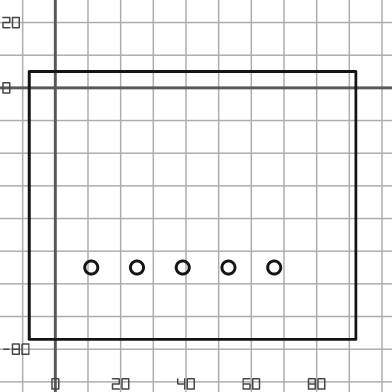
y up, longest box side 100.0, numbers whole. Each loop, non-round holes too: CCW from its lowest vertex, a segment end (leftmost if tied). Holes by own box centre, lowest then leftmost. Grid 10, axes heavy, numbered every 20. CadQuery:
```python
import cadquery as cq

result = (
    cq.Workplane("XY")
    .moveTo(-8.0, -77.0)
    .lineTo(92.0, -77.0)
    .lineTo(92.0, 5.0)
    .lineTo(-8.0, 5.0)
    .close()
    .moveTo(11.0, -55.0)
    .circle(2.0)
    .moveTo(25.0, -55.0)
    .circle(2.0)
    .moveTo(39.0, -55.0)
    .circle(2.0)
    .moveTo(53.0, -55.0)
    .circle(2.0)
    .moveTo(67.0, -55.0)
    .circle(2.0)
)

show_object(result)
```